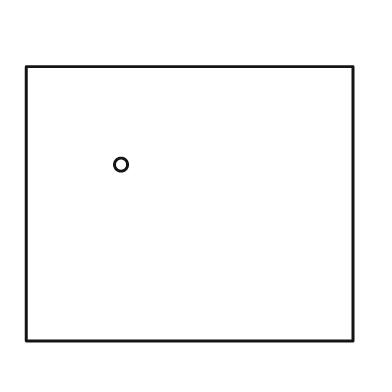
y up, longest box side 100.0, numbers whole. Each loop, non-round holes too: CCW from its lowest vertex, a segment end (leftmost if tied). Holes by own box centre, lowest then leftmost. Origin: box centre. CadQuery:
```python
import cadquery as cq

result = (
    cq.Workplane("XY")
    .moveTo(-50.0, -42.0)
    .lineTo(50.0, -42.0)
    .lineTo(50.0, 42.0)
    .lineTo(-50.0, 42.0)
    .close()
    .moveTo(-21.0, 12.0)
    .circle(2.0)
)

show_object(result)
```